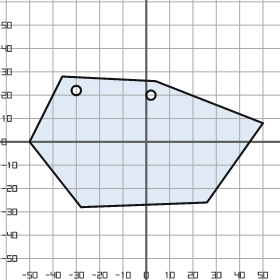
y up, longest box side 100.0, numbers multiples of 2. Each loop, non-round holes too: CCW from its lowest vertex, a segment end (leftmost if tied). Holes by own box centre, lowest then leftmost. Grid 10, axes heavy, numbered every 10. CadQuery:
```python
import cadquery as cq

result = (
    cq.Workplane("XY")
    .moveTo(-28.0, -28.0)
    .lineTo(26.0, -26.0)
    .lineTo(50.0, 8.0)
    .lineTo(4.0, 26.0)
    .lineTo(-36.0, 28.0)
    .lineTo(-50.0, 0.0)
    .close()
    .moveTo(2.0, 20.0)
    .circle(2.0)
    .moveTo(-30.0, 22.0)
    .circle(2.0)
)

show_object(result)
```